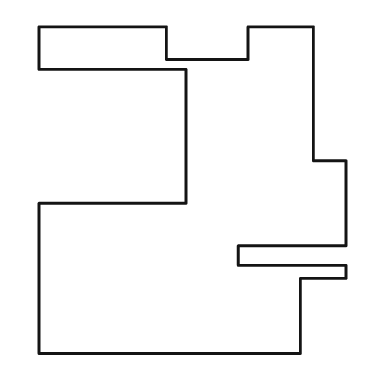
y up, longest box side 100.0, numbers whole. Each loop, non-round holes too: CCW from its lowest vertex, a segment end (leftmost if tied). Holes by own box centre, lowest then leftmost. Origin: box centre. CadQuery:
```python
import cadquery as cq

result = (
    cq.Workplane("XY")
    .moveTo(-47.0, -50.0)
    .lineTo(33.0, -50.0)
    .lineTo(33.0, -27.0)
    .lineTo(47.0, -27.0)
    .lineTo(47.0, -23.0)
    .lineTo(14.0, -23.0)
    .lineTo(14.0, -17.0)
    .lineTo(47.0, -17.0)
    .lineTo(47.0, 9.0)
    .lineTo(37.0, 9.0)
    .lineTo(37.0, 50.0)
    .lineTo(17.0, 50.0)
    .lineTo(17.0, 40.0)
    .lineTo(-8.0, 40.0)
    .lineTo(-8.0, 50.0)
    .lineTo(-47.0, 50.0)
    .lineTo(-47.0, 37.0)
    .lineTo(-2.0, 37.0)
    .lineTo(-2.0, -4.0)
    .lineTo(-47.0, -4.0)
    .close()
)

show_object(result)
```